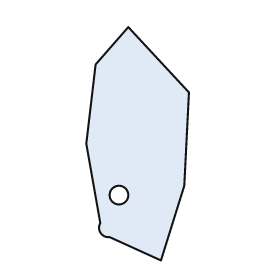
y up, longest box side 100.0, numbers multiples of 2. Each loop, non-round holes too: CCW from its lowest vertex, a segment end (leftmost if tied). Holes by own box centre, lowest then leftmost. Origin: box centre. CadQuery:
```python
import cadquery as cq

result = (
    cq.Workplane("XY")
    .moveTo(10.0, -50.0)
    .lineTo(20.0, -18.0)
    .lineTo(22.0, 22.0)
    .lineTo(-4.0, 50.0)
    .lineTo(-18.0, 34.0)
    .lineTo(-22.0, 0.0)
    .lineTo(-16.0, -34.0)
    .threePointArc((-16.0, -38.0), (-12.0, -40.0))
    .close()
    .moveTo(-8.0, -22.0)
    .circle(4.0)
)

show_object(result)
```